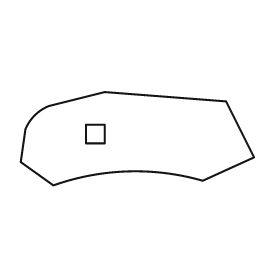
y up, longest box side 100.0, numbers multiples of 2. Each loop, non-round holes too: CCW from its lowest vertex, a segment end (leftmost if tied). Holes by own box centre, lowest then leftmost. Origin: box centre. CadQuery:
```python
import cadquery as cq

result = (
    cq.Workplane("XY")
    .moveTo(-36.0, -20.0)
    .threePointArc((-4.0, -14.0), (28.0, -18.0))
    .lineTo(50.0, -8.0)
    .lineTo(38.0, 16.0)
    .lineTo(-14.0, 20.0)
    .lineTo(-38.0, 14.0)
    .threePointArc((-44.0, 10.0), (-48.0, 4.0))
    .lineTo(-50.0, -10.0)
    .close()
    .moveTo(-22.0, -2.0)
    .lineTo(-14.0, -2.0)
    .lineTo(-14.0, 6.0)
    .lineTo(-22.0, 6.0)
    .close()
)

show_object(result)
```